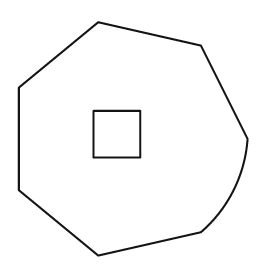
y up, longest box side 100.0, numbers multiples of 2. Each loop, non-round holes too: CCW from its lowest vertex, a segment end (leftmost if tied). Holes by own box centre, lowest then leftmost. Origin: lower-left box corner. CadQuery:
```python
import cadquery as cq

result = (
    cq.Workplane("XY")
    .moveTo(34.0, 0.0)
    .lineTo(78.0, 10.0)
    .threePointArc((92.0, 28.0), (98.0, 50.0))
    .lineTo(78.0, 90.0)
    .lineTo(34.0, 100.0)
    .lineTo(0.0, 72.0)
    .lineTo(0.0, 28.0)
    .close()
    .moveTo(32.0, 42.0)
    .lineTo(52.0, 42.0)
    .lineTo(52.0, 62.0)
    .lineTo(32.0, 62.0)
    .close()
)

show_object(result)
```